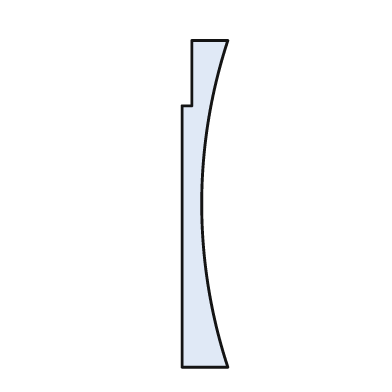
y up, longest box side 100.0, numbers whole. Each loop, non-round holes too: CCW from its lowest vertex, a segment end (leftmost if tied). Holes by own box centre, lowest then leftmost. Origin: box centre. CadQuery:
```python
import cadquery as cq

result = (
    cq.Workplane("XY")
    .moveTo(-7.0, -50.0)
    .lineTo(7.0, -50.0)
    .threePointArc((-1.0, 0.0), (7.0, 50.0))
    .lineTo(-4.0, 50.0)
    .lineTo(-4.0, 30.0)
    .lineTo(-7.0, 30.0)
    .close()
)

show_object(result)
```